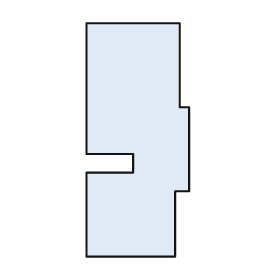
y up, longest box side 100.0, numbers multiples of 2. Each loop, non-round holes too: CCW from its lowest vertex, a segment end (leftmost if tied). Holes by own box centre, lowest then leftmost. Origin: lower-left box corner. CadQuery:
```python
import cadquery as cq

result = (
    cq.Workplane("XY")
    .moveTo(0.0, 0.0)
    .lineTo(38.0, 0.0)
    .lineTo(38.0, 28.0)
    .lineTo(44.0, 28.0)
    .lineTo(44.0, 64.0)
    .lineTo(40.0, 64.0)
    .lineTo(40.0, 100.0)
    .lineTo(0.0, 100.0)
    .lineTo(0.0, 44.0)
    .lineTo(20.0, 44.0)
    .lineTo(20.0, 36.0)
    .lineTo(0.0, 36.0)
    .close()
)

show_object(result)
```